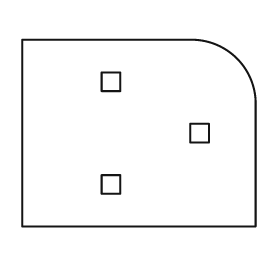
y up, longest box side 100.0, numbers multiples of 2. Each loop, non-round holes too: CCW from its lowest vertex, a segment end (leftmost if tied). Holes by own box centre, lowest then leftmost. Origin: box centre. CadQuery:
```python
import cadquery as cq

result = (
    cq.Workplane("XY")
    .moveTo(-50.0, -40.0)
    .lineTo(50.0, -40.0)
    .lineTo(50.0, 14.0)
    .threePointArc((42.0, 32.0), (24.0, 40.0))
    .lineTo(-50.0, 40.0)
    .close()
    .moveTo(-16.0, -26.0)
    .lineTo(-8.0, -26.0)
    .lineTo(-8.0, -18.0)
    .lineTo(-16.0, -18.0)
    .close()
    .moveTo(22.0, -4.0)
    .lineTo(30.0, -4.0)
    .lineTo(30.0, 4.0)
    .lineTo(22.0, 4.0)
    .close()
    .moveTo(-16.0, 18.0)
    .lineTo(-8.0, 18.0)
    .lineTo(-8.0, 26.0)
    .lineTo(-16.0, 26.0)
    .close()
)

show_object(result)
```